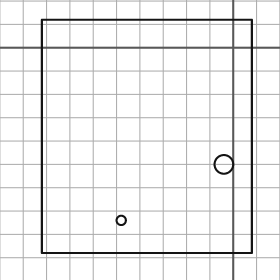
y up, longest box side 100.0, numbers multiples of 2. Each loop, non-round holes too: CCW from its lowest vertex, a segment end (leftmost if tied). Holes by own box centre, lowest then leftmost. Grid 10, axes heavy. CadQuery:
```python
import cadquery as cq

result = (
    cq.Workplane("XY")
    .moveTo(-82.0, -88.0)
    .lineTo(8.0, -88.0)
    .lineTo(8.0, 12.0)
    .lineTo(-82.0, 12.0)
    .close()
    .moveTo(-48.0, -74.0)
    .circle(2.0)
    .moveTo(-4.0, -50.0)
    .circle(4.0)
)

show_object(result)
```